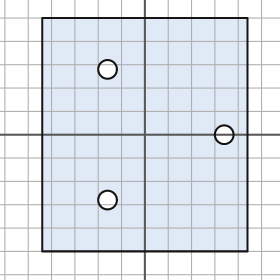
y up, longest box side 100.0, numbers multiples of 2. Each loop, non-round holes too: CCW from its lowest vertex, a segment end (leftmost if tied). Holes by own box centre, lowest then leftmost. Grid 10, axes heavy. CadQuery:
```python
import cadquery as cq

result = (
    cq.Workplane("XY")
    .moveTo(-44.0, -50.0)
    .lineTo(44.0, -50.0)
    .lineTo(44.0, 50.0)
    .lineTo(-44.0, 50.0)
    .close()
    .moveTo(-16.0, -28.0)
    .circle(4.0)
    .moveTo(34.0, 0.0)
    .circle(4.0)
    .moveTo(-16.0, 28.0)
    .circle(4.0)
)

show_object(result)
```